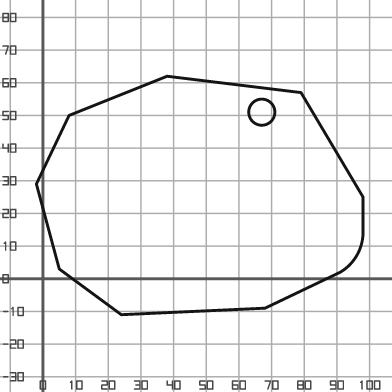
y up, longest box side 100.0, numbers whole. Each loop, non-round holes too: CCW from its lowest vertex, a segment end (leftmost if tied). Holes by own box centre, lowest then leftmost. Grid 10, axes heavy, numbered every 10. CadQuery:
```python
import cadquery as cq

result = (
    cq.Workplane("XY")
    .moveTo(24.0, -11.0)
    .lineTo(68.0, -9.0)
    .lineTo(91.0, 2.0)
    .threePointArc((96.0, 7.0), (98.0, 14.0))
    .lineTo(98.0, 25.0)
    .lineTo(79.0, 57.0)
    .lineTo(38.0, 62.0)
    .lineTo(8.0, 50.0)
    .lineTo(-2.0, 29.0)
    .lineTo(5.0, 3.0)
    .close()
    .moveTo(67.0, 51.0)
    .circle(4.0)
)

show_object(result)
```